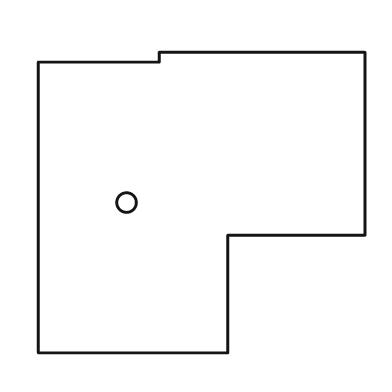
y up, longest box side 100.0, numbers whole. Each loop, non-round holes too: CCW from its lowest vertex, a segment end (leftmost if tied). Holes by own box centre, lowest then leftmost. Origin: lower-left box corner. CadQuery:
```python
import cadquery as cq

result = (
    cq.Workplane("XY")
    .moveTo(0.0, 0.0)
    .lineTo(58.0, 0.0)
    .lineTo(58.0, 36.0)
    .lineTo(100.0, 36.0)
    .lineTo(100.0, 92.0)
    .lineTo(37.0, 92.0)
    .lineTo(37.0, 89.0)
    .lineTo(0.0, 89.0)
    .close()
    .moveTo(27.0, 46.0)
    .circle(3.0)
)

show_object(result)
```